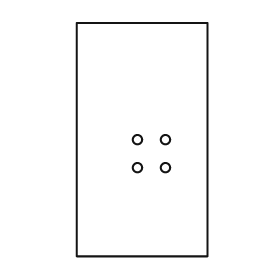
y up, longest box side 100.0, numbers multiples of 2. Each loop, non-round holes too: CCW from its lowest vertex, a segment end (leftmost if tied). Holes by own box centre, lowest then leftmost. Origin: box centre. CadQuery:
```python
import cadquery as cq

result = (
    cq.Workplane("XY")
    .moveTo(-28.0, -50.0)
    .lineTo(28.0, -50.0)
    .lineTo(28.0, 50.0)
    .lineTo(-28.0, 50.0)
    .close()
    .moveTo(-2.0, -12.0)
    .circle(2.0)
    .moveTo(10.0, -12.0)
    .circle(2.0)
    .moveTo(-2.0, 0.0)
    .circle(2.0)
    .moveTo(10.0, 0.0)
    .circle(2.0)
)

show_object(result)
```